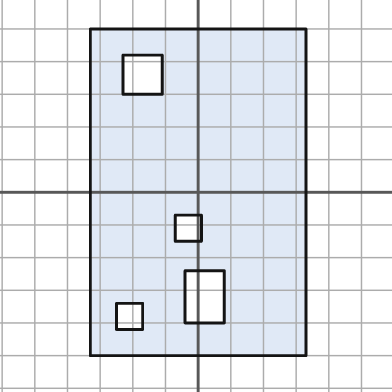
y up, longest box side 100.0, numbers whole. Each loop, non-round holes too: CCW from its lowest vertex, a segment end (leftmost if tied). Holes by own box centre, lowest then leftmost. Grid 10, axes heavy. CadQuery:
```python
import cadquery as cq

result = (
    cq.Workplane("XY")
    .moveTo(-33.0, -50.0)
    .lineTo(33.0, -50.0)
    .lineTo(33.0, 50.0)
    .lineTo(-33.0, 50.0)
    .close()
    .moveTo(-25.0, -42.0)
    .lineTo(-17.0, -42.0)
    .lineTo(-17.0, -34.0)
    .lineTo(-25.0, -34.0)
    .close()
    .moveTo(-4.0, -40.0)
    .lineTo(8.0, -40.0)
    .lineTo(8.0, -24.0)
    .lineTo(-4.0, -24.0)
    .close()
    .moveTo(-7.0, -15.0)
    .lineTo(1.0, -15.0)
    .lineTo(1.0, -7.0)
    .lineTo(-7.0, -7.0)
    .close()
    .moveTo(-23.0, 30.0)
    .lineTo(-11.0, 30.0)
    .lineTo(-11.0, 42.0)
    .lineTo(-23.0, 42.0)
    .close()
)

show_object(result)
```